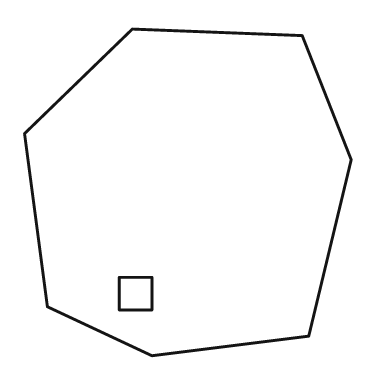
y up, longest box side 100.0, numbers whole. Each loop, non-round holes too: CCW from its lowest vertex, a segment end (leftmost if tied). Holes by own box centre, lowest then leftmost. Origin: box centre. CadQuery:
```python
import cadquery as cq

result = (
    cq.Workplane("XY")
    .moveTo(-11.0, -50.0)
    .lineTo(37.0, -44.0)
    .lineTo(50.0, 10.0)
    .lineTo(35.0, 48.0)
    .lineTo(-17.0, 50.0)
    .lineTo(-50.0, 18.0)
    .lineTo(-43.0, -35.0)
    .close()
    .moveTo(-21.0, -36.0)
    .lineTo(-11.0, -36.0)
    .lineTo(-11.0, -26.0)
    .lineTo(-21.0, -26.0)
    .close()
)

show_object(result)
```